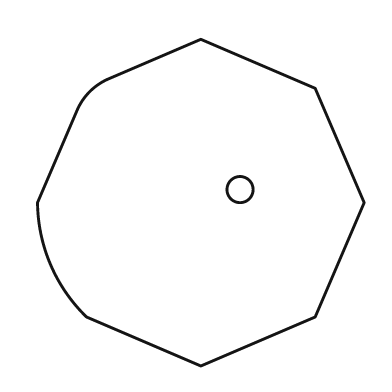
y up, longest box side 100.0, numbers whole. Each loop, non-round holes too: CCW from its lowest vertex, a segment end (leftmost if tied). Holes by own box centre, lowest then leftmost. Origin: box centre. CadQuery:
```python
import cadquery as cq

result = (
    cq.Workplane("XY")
    .moveTo(0.0, -50.0)
    .lineTo(35.0, -35.0)
    .lineTo(50.0, 0.0)
    .lineTo(35.0, 35.0)
    .lineTo(0.0, 50.0)
    .lineTo(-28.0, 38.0)
    .threePointArc((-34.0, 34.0), (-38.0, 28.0))
    .lineTo(-50.0, 0.0)
    .threePointArc((-46.0, -19.0), (-35.0, -35.0))
    .close()
    .moveTo(12.0, 4.0)
    .circle(4.0)
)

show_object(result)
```